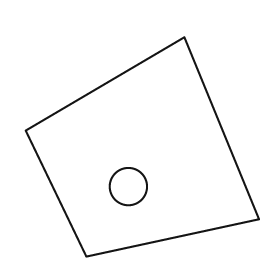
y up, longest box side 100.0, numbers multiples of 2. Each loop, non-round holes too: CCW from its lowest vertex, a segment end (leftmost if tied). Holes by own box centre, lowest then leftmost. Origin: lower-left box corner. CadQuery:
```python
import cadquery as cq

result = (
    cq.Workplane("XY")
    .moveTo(26.0, 0.0)
    .lineTo(100.0, 16.0)
    .lineTo(68.0, 94.0)
    .lineTo(0.0, 54.0)
    .close()
    .moveTo(44.0, 30.0)
    .circle(8.0)
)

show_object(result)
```